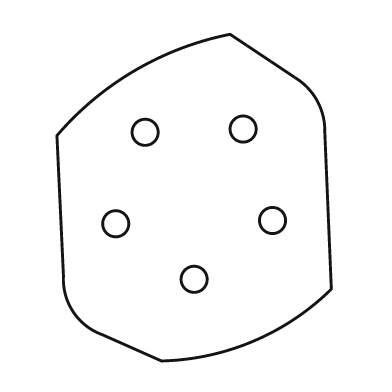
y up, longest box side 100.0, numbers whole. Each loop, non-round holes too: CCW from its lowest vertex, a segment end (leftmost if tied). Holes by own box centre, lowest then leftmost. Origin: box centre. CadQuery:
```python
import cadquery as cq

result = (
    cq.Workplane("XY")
    .moveTo(-10.0, -50.0)
    .threePointArc((18.0, -44.0), (42.0, -28.0))
    .lineTo(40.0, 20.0)
    .threePointArc((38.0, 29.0), (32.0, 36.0))
    .lineTo(11.0, 50.0)
    .threePointArc((-18.0, 39.0), (-42.0, 19.0))
    .lineTo(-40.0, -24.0)
    .threePointArc((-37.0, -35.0), (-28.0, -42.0))
    .close()
    .moveTo(0.0, -25.0)
    .circle(4.0)
    .moveTo(-24.0, -8.0)
    .circle(4.0)
    .moveTo(24.0, -7.0)
    .circle(4.0)
    .moveTo(-15.0, 20.0)
    .circle(4.0)
    .moveTo(15.0, 21.0)
    .circle(4.0)
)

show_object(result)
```